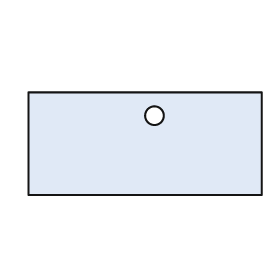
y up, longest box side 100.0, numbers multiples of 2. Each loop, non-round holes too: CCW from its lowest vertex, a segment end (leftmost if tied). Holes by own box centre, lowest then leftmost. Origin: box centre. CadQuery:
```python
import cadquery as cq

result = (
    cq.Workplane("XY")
    .moveTo(-50.0, -22.0)
    .lineTo(50.0, -22.0)
    .lineTo(50.0, 22.0)
    .lineTo(-50.0, 22.0)
    .close()
    .moveTo(4.0, 12.0)
    .circle(4.0)
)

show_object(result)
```